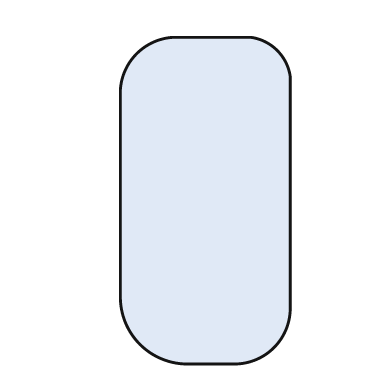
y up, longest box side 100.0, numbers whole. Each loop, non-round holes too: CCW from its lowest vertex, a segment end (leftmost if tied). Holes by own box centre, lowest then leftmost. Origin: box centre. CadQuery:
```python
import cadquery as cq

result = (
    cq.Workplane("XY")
    .moveTo(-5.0, -50.0)
    .lineTo(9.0, -50.0)
    .threePointArc((21.0, -45.0), (26.0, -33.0))
    .lineTo(26.0, 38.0)
    .threePointArc((22.0, 46.0), (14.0, 50.0))
    .lineTo(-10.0, 50.0)
    .threePointArc((-21.0, 45.0), (-26.0, 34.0))
    .lineTo(-26.0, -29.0)
    .threePointArc((-20.0, -44.0), (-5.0, -50.0))
    .close()
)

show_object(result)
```